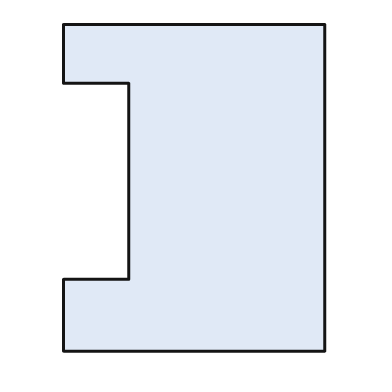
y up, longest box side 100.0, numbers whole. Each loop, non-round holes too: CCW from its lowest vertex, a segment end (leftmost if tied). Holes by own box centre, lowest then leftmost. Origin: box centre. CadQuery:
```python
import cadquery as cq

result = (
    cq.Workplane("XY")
    .moveTo(-40.0, -50.0)
    .lineTo(40.0, -50.0)
    .lineTo(40.0, 50.0)
    .lineTo(-40.0, 50.0)
    .lineTo(-40.0, 32.0)
    .lineTo(-20.0, 32.0)
    .lineTo(-20.0, -28.0)
    .lineTo(-40.0, -28.0)
    .close()
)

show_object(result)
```